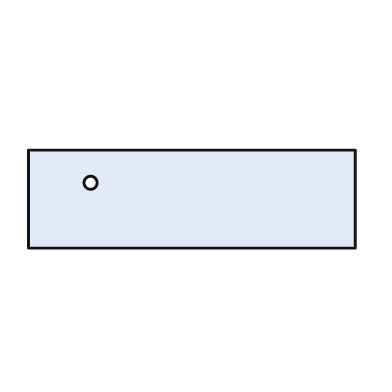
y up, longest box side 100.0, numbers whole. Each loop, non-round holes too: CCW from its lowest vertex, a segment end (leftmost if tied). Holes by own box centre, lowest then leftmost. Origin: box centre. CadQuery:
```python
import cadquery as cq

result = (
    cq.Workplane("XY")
    .moveTo(-50.0, -15.0)
    .lineTo(50.0, -15.0)
    .lineTo(50.0, 15.0)
    .lineTo(-50.0, 15.0)
    .close()
    .moveTo(-31.0, 5.0)
    .circle(2.0)
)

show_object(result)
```